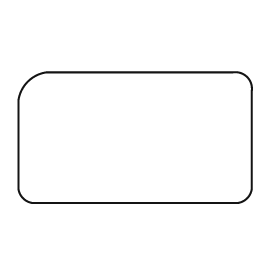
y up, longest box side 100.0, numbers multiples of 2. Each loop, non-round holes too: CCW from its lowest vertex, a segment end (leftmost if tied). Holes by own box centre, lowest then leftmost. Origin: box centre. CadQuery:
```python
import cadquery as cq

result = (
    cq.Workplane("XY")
    .moveTo(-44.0, -28.0)
    .lineTo(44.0, -28.0)
    .threePointArc((48.0, -26.0), (50.0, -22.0))
    .lineTo(50.0, 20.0)
    .threePointArc((48.0, 26.0), (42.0, 28.0))
    .lineTo(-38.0, 28.0)
    .threePointArc((-46.0, 24.0), (-50.0, 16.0))
    .lineTo(-50.0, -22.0)
    .threePointArc((-48.0, -26.0), (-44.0, -28.0))
    .close()
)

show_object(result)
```